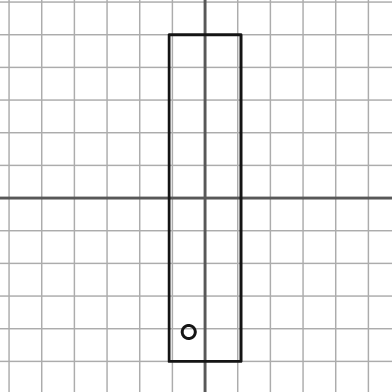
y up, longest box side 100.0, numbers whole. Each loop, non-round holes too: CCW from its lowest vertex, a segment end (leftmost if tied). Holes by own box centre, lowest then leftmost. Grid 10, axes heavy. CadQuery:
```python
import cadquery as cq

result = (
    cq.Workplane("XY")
    .moveTo(-11.0, -50.0)
    .lineTo(11.0, -50.0)
    .lineTo(11.0, 50.0)
    .lineTo(-11.0, 50.0)
    .close()
    .moveTo(-5.0, -41.0)
    .circle(2.0)
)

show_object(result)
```